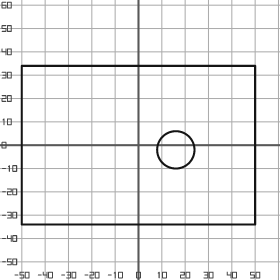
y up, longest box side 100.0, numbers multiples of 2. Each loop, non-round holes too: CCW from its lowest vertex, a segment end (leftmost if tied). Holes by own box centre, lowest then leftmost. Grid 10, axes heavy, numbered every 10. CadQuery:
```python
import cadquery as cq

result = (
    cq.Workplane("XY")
    .moveTo(-50.0, -34.0)
    .lineTo(50.0, -34.0)
    .lineTo(50.0, 34.0)
    .lineTo(-50.0, 34.0)
    .close()
    .moveTo(16.0, -2.0)
    .circle(8.0)
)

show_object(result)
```